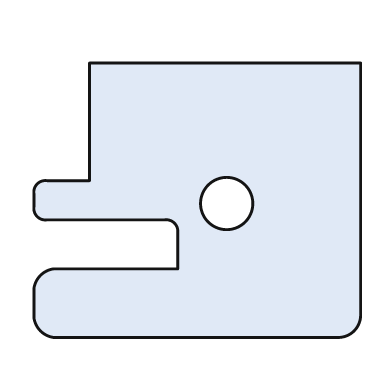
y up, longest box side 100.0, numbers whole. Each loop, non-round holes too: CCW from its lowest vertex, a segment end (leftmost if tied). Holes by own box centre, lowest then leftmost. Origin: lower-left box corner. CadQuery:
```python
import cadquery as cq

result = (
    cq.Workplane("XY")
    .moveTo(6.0, 0.0)
    .lineTo(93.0, 0.0)
    .threePointArc((98.0, 2.0), (100.0, 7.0))
    .lineTo(100.0, 84.0)
    .lineTo(17.0, 84.0)
    .lineTo(17.0, 48.0)
    .lineTo(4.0, 48.0)
    .threePointArc((1.0, 47.0), (0.0, 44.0))
    .lineTo(0.0, 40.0)
    .threePointArc((1.0, 37.0), (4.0, 36.0))
    .lineTo(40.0, 36.0)
    .threePointArc((43.0, 35.0), (44.0, 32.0))
    .lineTo(44.0, 21.0)
    .lineTo(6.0, 21.0)
    .threePointArc((2.0, 19.0), (0.0, 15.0))
    .lineTo(0.0, 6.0)
    .threePointArc((2.0, 2.0), (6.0, 0.0))
    .close()
    .moveTo(59.0, 41.0)
    .circle(8.0)
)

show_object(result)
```